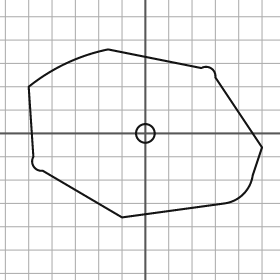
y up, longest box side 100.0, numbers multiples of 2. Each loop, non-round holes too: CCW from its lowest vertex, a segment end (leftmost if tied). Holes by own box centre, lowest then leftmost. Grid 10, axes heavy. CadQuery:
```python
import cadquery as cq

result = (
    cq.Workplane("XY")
    .moveTo(-10.0, -36.0)
    .lineTo(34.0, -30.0)
    .threePointArc((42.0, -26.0), (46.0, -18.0))
    .lineTo(50.0, -6.0)
    .lineTo(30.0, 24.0)
    .threePointArc((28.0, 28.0), (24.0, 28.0))
    .lineTo(-16.0, 36.0)
    .threePointArc((-34.0, 30.0), (-50.0, 20.0))
    .lineTo(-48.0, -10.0)
    .threePointArc((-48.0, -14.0), (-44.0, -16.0))
    .close()
    .moveTo(0.0, 0.0)
    .circle(4.0)
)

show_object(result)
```